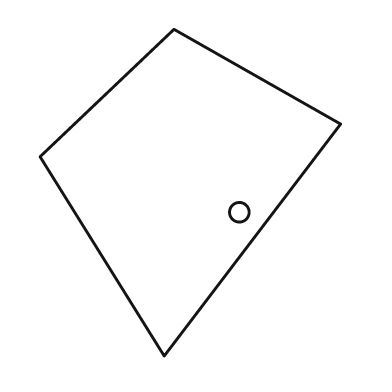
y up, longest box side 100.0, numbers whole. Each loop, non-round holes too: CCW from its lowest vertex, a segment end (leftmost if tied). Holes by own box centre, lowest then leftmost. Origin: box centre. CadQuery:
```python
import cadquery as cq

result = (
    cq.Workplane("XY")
    .moveTo(-8.0, -50.0)
    .lineTo(46.0, 21.0)
    .lineTo(-5.0, 50.0)
    .lineTo(-46.0, 11.0)
    .close()
    .moveTo(15.0, -6.0)
    .circle(3.0)
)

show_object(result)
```